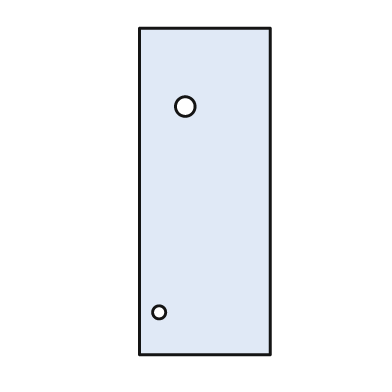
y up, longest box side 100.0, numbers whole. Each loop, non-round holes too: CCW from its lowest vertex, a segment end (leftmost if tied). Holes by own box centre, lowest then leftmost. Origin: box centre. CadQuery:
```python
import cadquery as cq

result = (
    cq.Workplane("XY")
    .moveTo(-20.0, -50.0)
    .lineTo(20.0, -50.0)
    .lineTo(20.0, 50.0)
    .lineTo(-20.0, 50.0)
    .close()
    .moveTo(-14.0, -37.0)
    .circle(2.0)
    .moveTo(-6.0, 26.0)
    .circle(3.0)
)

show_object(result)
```